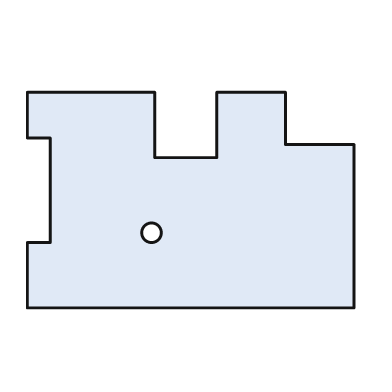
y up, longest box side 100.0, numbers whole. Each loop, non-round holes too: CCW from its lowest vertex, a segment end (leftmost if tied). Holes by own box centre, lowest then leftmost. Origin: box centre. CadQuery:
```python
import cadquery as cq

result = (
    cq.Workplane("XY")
    .moveTo(-50.0, -33.0)
    .lineTo(50.0, -33.0)
    .lineTo(50.0, 17.0)
    .lineTo(29.0, 17.0)
    .lineTo(29.0, 33.0)
    .lineTo(8.0, 33.0)
    .lineTo(8.0, 13.0)
    .lineTo(-11.0, 13.0)
    .lineTo(-11.0, 33.0)
    .lineTo(-50.0, 33.0)
    .lineTo(-50.0, 19.0)
    .lineTo(-43.0, 19.0)
    .lineTo(-43.0, -13.0)
    .lineTo(-50.0, -13.0)
    .close()
    .moveTo(-12.0, -10.0)
    .circle(3.0)
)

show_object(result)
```